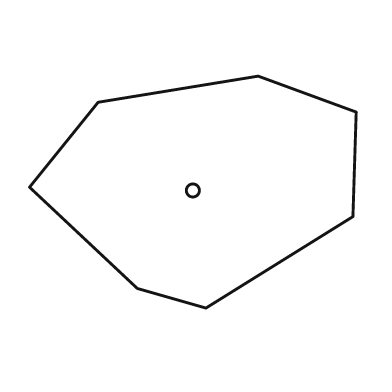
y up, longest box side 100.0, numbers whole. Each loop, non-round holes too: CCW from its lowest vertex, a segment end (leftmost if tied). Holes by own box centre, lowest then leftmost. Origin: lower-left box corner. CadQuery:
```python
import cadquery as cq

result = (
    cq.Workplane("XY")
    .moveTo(54.0, 0.0)
    .lineTo(99.0, 28.0)
    .lineTo(100.0, 60.0)
    .lineTo(70.0, 71.0)
    .lineTo(21.0, 63.0)
    .lineTo(0.0, 37.0)
    .lineTo(33.0, 6.0)
    .close()
    .moveTo(50.0, 36.0)
    .circle(2.0)
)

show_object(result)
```